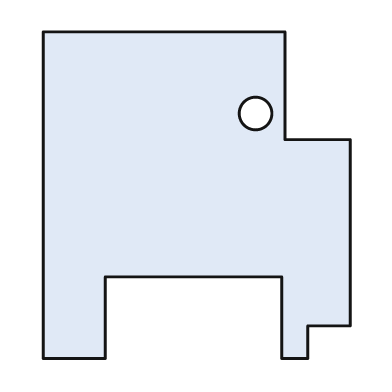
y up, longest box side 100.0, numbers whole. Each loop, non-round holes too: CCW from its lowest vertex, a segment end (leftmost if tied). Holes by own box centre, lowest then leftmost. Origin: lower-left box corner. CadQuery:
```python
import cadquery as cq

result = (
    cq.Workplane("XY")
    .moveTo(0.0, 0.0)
    .lineTo(19.0, 0.0)
    .lineTo(19.0, 25.0)
    .lineTo(73.0, 25.0)
    .lineTo(73.0, 0.0)
    .lineTo(81.0, 0.0)
    .lineTo(81.0, 10.0)
    .lineTo(94.0, 10.0)
    .lineTo(94.0, 67.0)
    .lineTo(74.0, 67.0)
    .lineTo(74.0, 100.0)
    .lineTo(0.0, 100.0)
    .close()
    .moveTo(65.0, 75.0)
    .circle(5.0)
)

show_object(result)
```